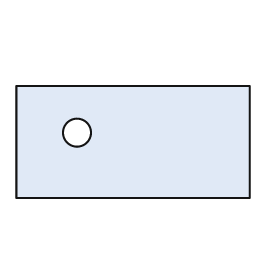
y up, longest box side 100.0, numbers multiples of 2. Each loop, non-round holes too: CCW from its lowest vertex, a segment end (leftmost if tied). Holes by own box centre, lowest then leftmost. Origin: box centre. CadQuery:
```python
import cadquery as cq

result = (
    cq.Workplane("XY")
    .moveTo(-50.0, -24.0)
    .lineTo(50.0, -24.0)
    .lineTo(50.0, 24.0)
    .lineTo(-50.0, 24.0)
    .close()
    .moveTo(-24.0, 4.0)
    .circle(6.0)
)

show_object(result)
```